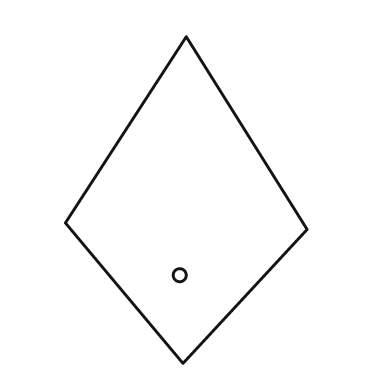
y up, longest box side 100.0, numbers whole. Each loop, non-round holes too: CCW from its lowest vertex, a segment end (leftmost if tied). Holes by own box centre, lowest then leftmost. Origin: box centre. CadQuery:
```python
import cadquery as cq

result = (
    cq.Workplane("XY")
    .moveTo(-1.0, -50.0)
    .lineTo(37.0, -9.0)
    .lineTo(0.0, 50.0)
    .lineTo(-37.0, -7.0)
    .close()
    .moveTo(-2.0, -23.0)
    .circle(2.0)
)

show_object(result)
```